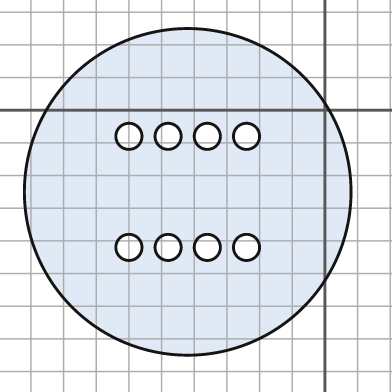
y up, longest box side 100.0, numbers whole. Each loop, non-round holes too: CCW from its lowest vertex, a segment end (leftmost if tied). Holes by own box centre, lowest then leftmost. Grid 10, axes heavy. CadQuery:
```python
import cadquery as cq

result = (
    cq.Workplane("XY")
    .moveTo(-42.0, -25.0)
    .circle(50.0)
    .moveTo(-60.0, -42.0)
    .circle(4.0)
    .moveTo(-48.0, -42.0)
    .circle(4.0)
    .moveTo(-36.0, -42.0)
    .circle(4.0)
    .moveTo(-24.0, -42.0)
    .circle(4.0)
    .moveTo(-60.0, -8.0)
    .circle(4.0)
    .moveTo(-48.0, -8.0)
    .circle(4.0)
    .moveTo(-36.0, -8.0)
    .circle(4.0)
    .moveTo(-24.0, -8.0)
    .circle(4.0)
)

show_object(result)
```